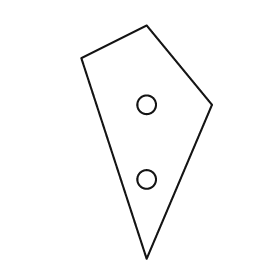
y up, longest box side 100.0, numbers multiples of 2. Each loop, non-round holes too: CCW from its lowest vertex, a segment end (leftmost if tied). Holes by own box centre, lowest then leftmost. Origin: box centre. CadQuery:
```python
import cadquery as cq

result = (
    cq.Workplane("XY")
    .moveTo(0.0, -50.0)
    .lineTo(28.0, 16.0)
    .lineTo(0.0, 50.0)
    .lineTo(-28.0, 36.0)
    .close()
    .moveTo(0.0, -16.0)
    .circle(4.0)
    .moveTo(0.0, 16.0)
    .circle(4.0)
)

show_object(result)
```